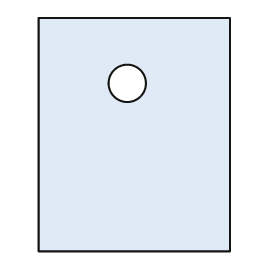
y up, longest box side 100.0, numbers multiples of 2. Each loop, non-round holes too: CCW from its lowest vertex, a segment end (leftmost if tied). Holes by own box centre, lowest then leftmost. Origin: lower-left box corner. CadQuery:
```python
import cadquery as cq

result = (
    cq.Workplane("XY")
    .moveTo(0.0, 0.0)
    .lineTo(82.0, 0.0)
    .lineTo(82.0, 100.0)
    .lineTo(0.0, 100.0)
    .close()
    .moveTo(38.0, 72.0)
    .circle(8.0)
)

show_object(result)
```